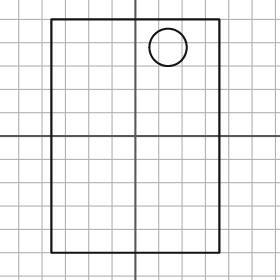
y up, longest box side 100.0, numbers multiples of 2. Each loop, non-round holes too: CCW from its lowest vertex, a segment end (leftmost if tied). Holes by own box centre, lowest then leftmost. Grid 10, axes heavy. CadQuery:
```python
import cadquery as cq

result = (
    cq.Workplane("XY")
    .moveTo(-36.0, -50.0)
    .lineTo(36.0, -50.0)
    .lineTo(36.0, 50.0)
    .lineTo(-36.0, 50.0)
    .close()
    .moveTo(14.0, 38.0)
    .circle(8.0)
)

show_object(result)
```